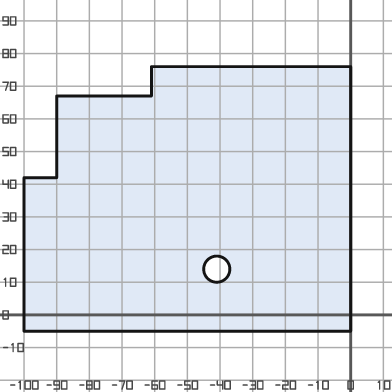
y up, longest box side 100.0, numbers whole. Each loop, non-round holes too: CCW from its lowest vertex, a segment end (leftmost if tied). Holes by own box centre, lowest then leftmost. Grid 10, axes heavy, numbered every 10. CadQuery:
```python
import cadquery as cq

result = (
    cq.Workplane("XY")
    .moveTo(-100.0, -5.0)
    .lineTo(0.0, -5.0)
    .lineTo(0.0, 76.0)
    .lineTo(-61.0, 76.0)
    .lineTo(-61.0, 67.0)
    .lineTo(-90.0, 67.0)
    .lineTo(-90.0, 42.0)
    .lineTo(-100.0, 42.0)
    .close()
    .moveTo(-41.0, 14.0)
    .circle(4.0)
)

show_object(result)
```